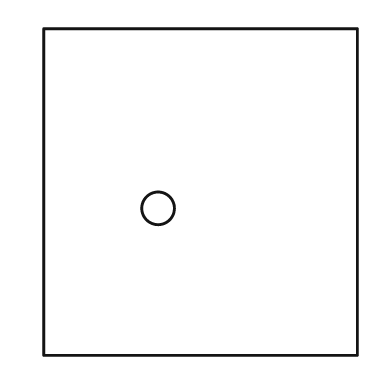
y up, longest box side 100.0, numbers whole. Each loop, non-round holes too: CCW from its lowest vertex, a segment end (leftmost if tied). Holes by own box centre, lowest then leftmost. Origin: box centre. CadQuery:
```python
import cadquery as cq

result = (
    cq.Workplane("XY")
    .moveTo(-48.0, -50.0)
    .lineTo(48.0, -50.0)
    .lineTo(48.0, 50.0)
    .lineTo(-48.0, 50.0)
    .close()
    .moveTo(-13.0, -5.0)
    .circle(5.0)
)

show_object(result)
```